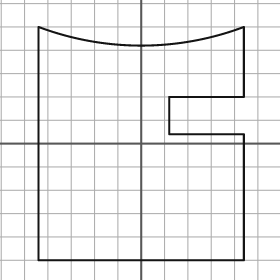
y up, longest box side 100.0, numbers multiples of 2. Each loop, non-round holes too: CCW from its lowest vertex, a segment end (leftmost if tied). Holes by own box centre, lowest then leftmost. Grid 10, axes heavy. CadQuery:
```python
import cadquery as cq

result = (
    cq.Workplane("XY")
    .moveTo(-44.0, -50.0)
    .lineTo(44.0, -50.0)
    .lineTo(44.0, 4.0)
    .lineTo(12.0, 4.0)
    .lineTo(12.0, 20.0)
    .lineTo(44.0, 20.0)
    .lineTo(44.0, 50.0)
    .threePointArc((0.0, 42.0), (-44.0, 50.0))
    .close()
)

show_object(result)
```